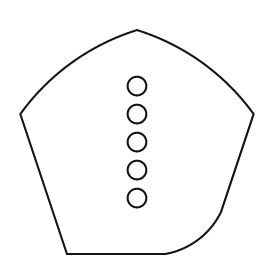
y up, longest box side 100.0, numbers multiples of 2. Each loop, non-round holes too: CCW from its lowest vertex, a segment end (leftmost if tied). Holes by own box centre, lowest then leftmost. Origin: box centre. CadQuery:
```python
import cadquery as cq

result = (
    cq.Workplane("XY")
    .moveTo(-30.0, -48.0)
    .lineTo(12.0, -48.0)
    .threePointArc((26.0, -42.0), (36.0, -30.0))
    .lineTo(50.0, 12.0)
    .threePointArc((28.0, 34.0), (0.0, 48.0))
    .threePointArc((-28.0, 34.0), (-50.0, 12.0))
    .close()
    .moveTo(0.0, -24.0)
    .circle(4.0)
    .moveTo(0.0, -12.0)
    .circle(4.0)
    .moveTo(0.0, 0.0)
    .circle(4.0)
    .moveTo(0.0, 12.0)
    .circle(4.0)
    .moveTo(0.0, 24.0)
    .circle(4.0)
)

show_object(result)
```